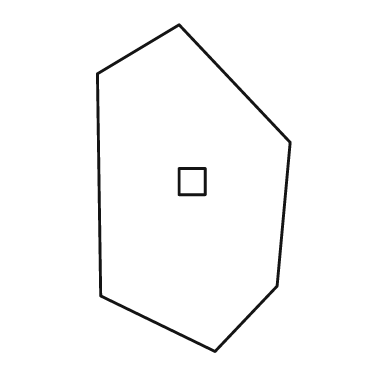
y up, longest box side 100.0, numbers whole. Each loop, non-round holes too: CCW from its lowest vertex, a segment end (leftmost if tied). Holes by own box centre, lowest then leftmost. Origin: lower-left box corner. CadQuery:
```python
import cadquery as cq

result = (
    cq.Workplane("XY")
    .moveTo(36.0, 0.0)
    .lineTo(55.0, 20.0)
    .lineTo(59.0, 64.0)
    .lineTo(25.0, 100.0)
    .lineTo(0.0, 85.0)
    .lineTo(1.0, 17.0)
    .close()
    .moveTo(25.0, 48.0)
    .lineTo(33.0, 48.0)
    .lineTo(33.0, 56.0)
    .lineTo(25.0, 56.0)
    .close()
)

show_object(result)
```